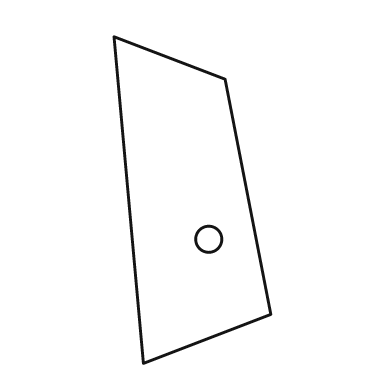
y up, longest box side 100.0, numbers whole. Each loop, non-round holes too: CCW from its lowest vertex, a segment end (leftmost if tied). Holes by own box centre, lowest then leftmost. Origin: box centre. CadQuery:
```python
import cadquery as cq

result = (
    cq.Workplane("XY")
    .moveTo(-15.0, -50.0)
    .lineTo(24.0, -35.0)
    .lineTo(10.0, 37.0)
    .lineTo(-24.0, 50.0)
    .close()
    .moveTo(5.0, -12.0)
    .circle(4.0)
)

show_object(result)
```